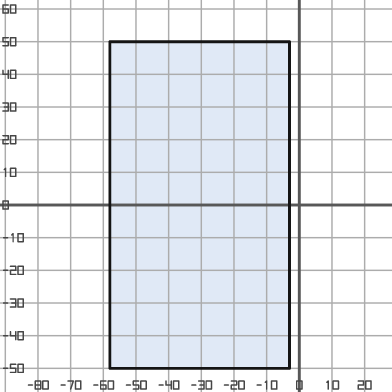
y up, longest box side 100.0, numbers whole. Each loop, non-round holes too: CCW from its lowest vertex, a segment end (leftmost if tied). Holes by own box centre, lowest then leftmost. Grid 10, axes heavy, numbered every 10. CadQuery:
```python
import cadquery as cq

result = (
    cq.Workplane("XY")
    .moveTo(-58.0, -50.0)
    .lineTo(-3.0, -50.0)
    .lineTo(-3.0, 50.0)
    .lineTo(-58.0, 50.0)
    .close()
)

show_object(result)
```